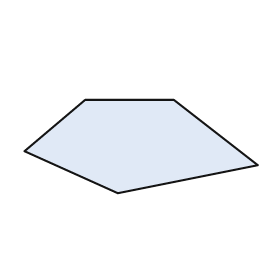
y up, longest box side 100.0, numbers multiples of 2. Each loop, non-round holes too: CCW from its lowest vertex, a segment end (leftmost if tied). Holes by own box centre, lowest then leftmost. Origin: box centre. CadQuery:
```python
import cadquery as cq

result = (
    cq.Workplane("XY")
    .moveTo(-10.0, -20.0)
    .lineTo(50.0, -8.0)
    .lineTo(14.0, 20.0)
    .lineTo(-24.0, 20.0)
    .lineTo(-50.0, -2.0)
    .close()
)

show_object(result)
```